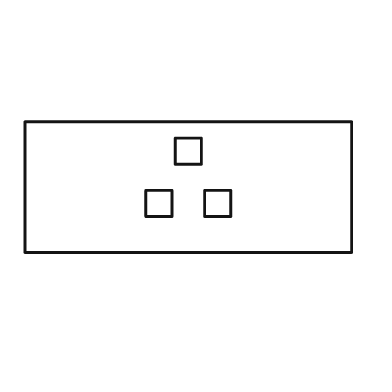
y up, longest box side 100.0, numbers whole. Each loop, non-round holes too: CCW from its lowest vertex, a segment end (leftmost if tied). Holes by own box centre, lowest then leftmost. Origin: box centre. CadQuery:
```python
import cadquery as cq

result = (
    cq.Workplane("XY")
    .moveTo(-50.0, -20.0)
    .lineTo(50.0, -20.0)
    .lineTo(50.0, 20.0)
    .lineTo(-50.0, 20.0)
    .close()
    .moveTo(-13.0, -9.0)
    .lineTo(-5.0, -9.0)
    .lineTo(-5.0, -1.0)
    .lineTo(-13.0, -1.0)
    .close()
    .moveTo(5.0, -9.0)
    .lineTo(13.0, -9.0)
    .lineTo(13.0, -1.0)
    .lineTo(5.0, -1.0)
    .close()
    .moveTo(-4.0, 7.0)
    .lineTo(4.0, 7.0)
    .lineTo(4.0, 15.0)
    .lineTo(-4.0, 15.0)
    .close()
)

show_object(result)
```